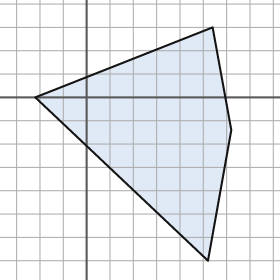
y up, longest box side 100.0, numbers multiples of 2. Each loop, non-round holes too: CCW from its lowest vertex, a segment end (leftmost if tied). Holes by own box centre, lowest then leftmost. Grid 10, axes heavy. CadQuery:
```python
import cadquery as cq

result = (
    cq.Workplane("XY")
    .moveTo(52.0, -70.0)
    .lineTo(62.0, -14.0)
    .lineTo(54.0, 30.0)
    .lineTo(-22.0, 0.0)
    .close()
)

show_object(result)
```